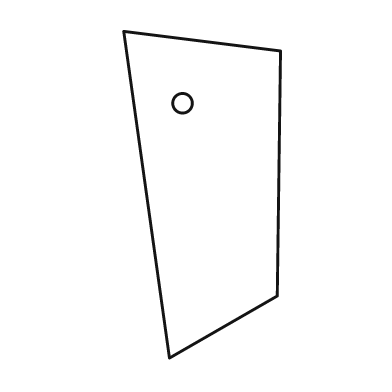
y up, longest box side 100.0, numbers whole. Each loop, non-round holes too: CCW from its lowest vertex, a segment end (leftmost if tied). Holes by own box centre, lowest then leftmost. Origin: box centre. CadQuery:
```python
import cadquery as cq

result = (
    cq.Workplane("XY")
    .moveTo(-10.0, -50.0)
    .lineTo(23.0, -31.0)
    .lineTo(24.0, 44.0)
    .lineTo(-24.0, 50.0)
    .close()
    .moveTo(-6.0, 28.0)
    .circle(3.0)
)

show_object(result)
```